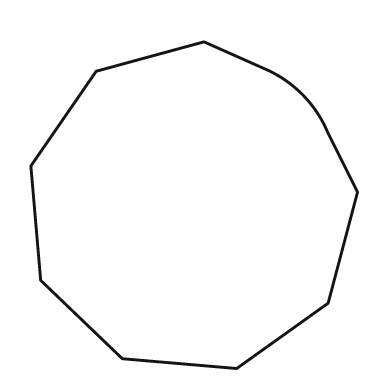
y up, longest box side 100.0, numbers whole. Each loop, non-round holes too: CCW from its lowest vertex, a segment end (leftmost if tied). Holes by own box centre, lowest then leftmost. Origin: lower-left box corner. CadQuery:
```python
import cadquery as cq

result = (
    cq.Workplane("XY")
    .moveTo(63.0, 0.0)
    .lineTo(91.0, 20.0)
    .lineTo(100.0, 54.0)
    .lineTo(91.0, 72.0)
    .threePointArc((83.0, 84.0), (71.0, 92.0))
    .lineTo(53.0, 100.0)
    .lineTo(20.0, 91.0)
    .lineTo(0.0, 62.0)
    .lineTo(3.0, 27.0)
    .lineTo(28.0, 3.0)
    .close()
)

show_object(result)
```